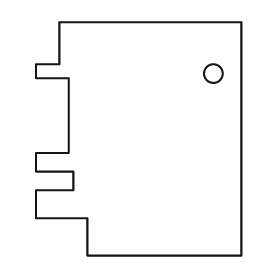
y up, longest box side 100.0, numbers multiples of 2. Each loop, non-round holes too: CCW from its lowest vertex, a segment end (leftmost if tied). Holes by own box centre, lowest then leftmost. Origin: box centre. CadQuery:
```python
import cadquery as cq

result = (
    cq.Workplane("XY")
    .moveTo(-22.0, -50.0)
    .lineTo(44.0, -50.0)
    .lineTo(44.0, 50.0)
    .lineTo(-34.0, 50.0)
    .lineTo(-34.0, 32.0)
    .lineTo(-44.0, 32.0)
    .lineTo(-44.0, 26.0)
    .lineTo(-30.0, 26.0)
    .lineTo(-30.0, -6.0)
    .lineTo(-44.0, -6.0)
    .lineTo(-44.0, -14.0)
    .lineTo(-28.0, -14.0)
    .lineTo(-28.0, -22.0)
    .lineTo(-44.0, -22.0)
    .lineTo(-44.0, -34.0)
    .lineTo(-22.0, -34.0)
    .close()
    .moveTo(32.0, 28.0)
    .circle(4.0)
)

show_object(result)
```